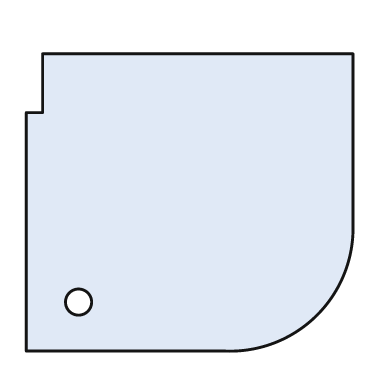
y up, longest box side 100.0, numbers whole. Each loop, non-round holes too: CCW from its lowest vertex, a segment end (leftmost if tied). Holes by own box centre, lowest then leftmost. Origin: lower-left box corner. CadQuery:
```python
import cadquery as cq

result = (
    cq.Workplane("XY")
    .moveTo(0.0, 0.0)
    .lineTo(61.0, 0.0)
    .threePointArc((89.0, 11.0), (100.0, 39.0))
    .lineTo(100.0, 91.0)
    .lineTo(5.0, 91.0)
    .lineTo(5.0, 73.0)
    .lineTo(0.0, 73.0)
    .close()
    .moveTo(16.0, 15.0)
    .circle(4.0)
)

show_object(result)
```